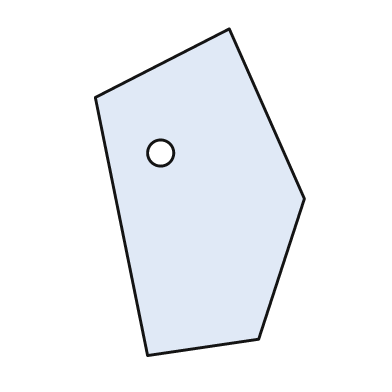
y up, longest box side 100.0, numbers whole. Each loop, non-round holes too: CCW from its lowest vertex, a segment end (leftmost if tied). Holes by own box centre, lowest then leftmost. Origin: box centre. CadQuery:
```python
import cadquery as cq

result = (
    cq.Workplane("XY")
    .moveTo(-16.0, -50.0)
    .lineTo(18.0, -45.0)
    .lineTo(32.0, -2.0)
    .lineTo(9.0, 50.0)
    .lineTo(-32.0, 29.0)
    .close()
    .moveTo(-12.0, 12.0)
    .circle(4.0)
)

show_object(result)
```